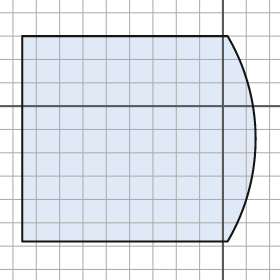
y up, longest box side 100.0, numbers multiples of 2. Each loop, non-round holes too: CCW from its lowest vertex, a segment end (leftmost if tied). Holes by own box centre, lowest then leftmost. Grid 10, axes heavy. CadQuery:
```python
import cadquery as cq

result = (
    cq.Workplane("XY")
    .moveTo(-86.0, -58.0)
    .lineTo(2.0, -58.0)
    .threePointArc((14.0, -14.0), (2.0, 30.0))
    .lineTo(-86.0, 30.0)
    .close()
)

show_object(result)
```